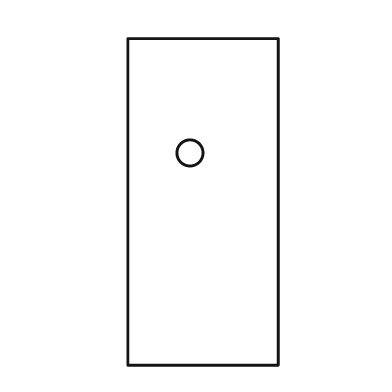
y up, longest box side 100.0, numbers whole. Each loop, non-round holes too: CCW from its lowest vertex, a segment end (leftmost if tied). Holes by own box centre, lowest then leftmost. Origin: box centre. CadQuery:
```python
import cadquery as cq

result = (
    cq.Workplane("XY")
    .moveTo(-23.0, -50.0)
    .lineTo(23.0, -50.0)
    .lineTo(23.0, 50.0)
    .lineTo(-23.0, 50.0)
    .close()
    .moveTo(-4.0, 15.0)
    .circle(4.0)
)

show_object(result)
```